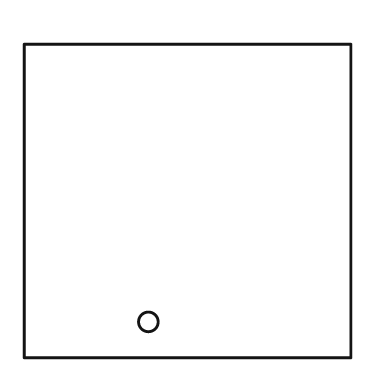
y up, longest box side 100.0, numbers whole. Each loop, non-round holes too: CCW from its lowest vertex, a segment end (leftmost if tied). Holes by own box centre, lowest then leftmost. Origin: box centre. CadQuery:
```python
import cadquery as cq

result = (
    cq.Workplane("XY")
    .moveTo(-50.0, -48.0)
    .lineTo(50.0, -48.0)
    .lineTo(50.0, 48.0)
    .lineTo(-50.0, 48.0)
    .close()
    .moveTo(-12.0, -37.0)
    .circle(3.0)
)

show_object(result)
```